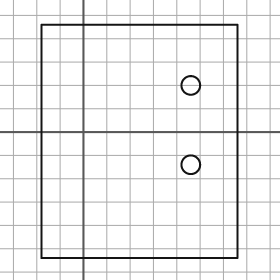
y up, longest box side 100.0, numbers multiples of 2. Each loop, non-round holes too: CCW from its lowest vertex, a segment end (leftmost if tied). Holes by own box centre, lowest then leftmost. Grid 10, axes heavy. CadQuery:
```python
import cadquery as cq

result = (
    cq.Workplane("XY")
    .moveTo(-18.0, -54.0)
    .lineTo(66.0, -54.0)
    .lineTo(66.0, 46.0)
    .lineTo(-18.0, 46.0)
    .close()
    .moveTo(46.0, -14.0)
    .circle(4.0)
    .moveTo(46.0, 20.0)
    .circle(4.0)
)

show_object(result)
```